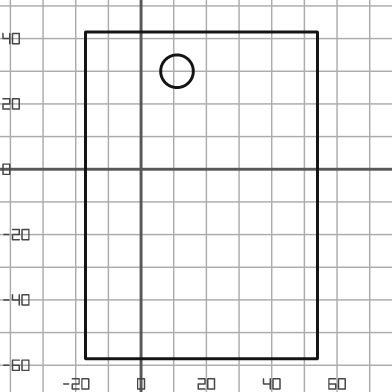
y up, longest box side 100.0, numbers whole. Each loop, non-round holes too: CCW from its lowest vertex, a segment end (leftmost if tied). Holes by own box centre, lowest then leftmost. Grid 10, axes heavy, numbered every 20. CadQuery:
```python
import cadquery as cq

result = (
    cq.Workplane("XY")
    .moveTo(-17.0, -58.0)
    .lineTo(54.0, -58.0)
    .lineTo(54.0, 42.0)
    .lineTo(-17.0, 42.0)
    .close()
    .moveTo(11.0, 30.0)
    .circle(5.0)
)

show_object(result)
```